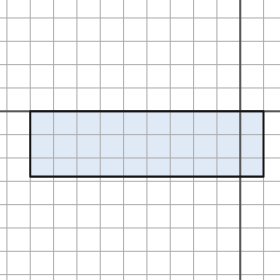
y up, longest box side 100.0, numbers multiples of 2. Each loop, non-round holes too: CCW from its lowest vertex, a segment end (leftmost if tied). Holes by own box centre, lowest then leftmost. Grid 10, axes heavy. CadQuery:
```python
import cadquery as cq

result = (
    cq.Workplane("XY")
    .moveTo(-90.0, -28.0)
    .lineTo(10.0, -28.0)
    .lineTo(10.0, 0.0)
    .lineTo(-90.0, 0.0)
    .close()
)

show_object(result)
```